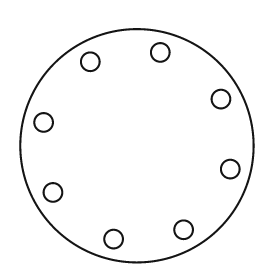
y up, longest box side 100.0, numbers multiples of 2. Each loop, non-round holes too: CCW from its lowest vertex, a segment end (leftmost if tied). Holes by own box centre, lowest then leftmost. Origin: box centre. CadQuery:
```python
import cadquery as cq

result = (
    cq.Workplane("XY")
    .moveTo(0.0, 0.0)
    .circle(50.0)
    .moveTo(-10.0, -40.0)
    .circle(4.0)
    .moveTo(20.0, -36.0)
    .circle(4.0)
    .moveTo(-36.0, -20.0)
    .circle(4.0)
    .moveTo(40.0, -10.0)
    .circle(4.0)
    .moveTo(-40.0, 10.0)
    .circle(4.0)
    .moveTo(36.0, 20.0)
    .circle(4.0)
    .moveTo(-20.0, 36.0)
    .circle(4.0)
    .moveTo(10.0, 40.0)
    .circle(4.0)
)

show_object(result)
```